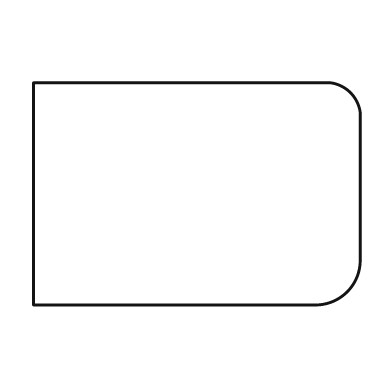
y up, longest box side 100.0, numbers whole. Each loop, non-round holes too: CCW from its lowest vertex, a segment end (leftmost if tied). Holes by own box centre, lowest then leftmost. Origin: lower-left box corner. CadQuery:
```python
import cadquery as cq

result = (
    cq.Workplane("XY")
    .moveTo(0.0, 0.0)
    .lineTo(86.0, 0.0)
    .threePointArc((96.0, 4.0), (100.0, 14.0))
    .lineTo(100.0, 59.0)
    .threePointArc((97.0, 65.0), (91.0, 68.0))
    .lineTo(0.0, 68.0)
    .close()
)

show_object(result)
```